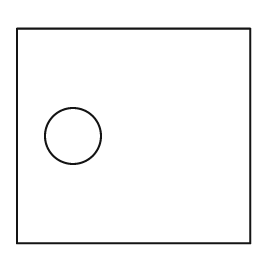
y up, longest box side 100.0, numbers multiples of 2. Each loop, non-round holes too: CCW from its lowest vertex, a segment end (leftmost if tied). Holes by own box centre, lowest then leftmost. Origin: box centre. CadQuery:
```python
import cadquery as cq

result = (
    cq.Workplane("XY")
    .moveTo(-50.0, -46.0)
    .lineTo(50.0, -46.0)
    .lineTo(50.0, 46.0)
    .lineTo(-50.0, 46.0)
    .close()
    .moveTo(-26.0, 0.0)
    .circle(12.0)
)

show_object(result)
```